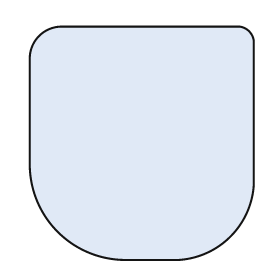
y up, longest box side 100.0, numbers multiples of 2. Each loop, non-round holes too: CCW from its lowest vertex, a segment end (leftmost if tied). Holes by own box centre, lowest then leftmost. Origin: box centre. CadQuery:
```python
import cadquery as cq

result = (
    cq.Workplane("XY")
    .moveTo(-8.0, -50.0)
    .lineTo(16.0, -50.0)
    .threePointArc((38.0, -40.0), (48.0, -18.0))
    .lineTo(48.0, 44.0)
    .threePointArc((46.0, 48.0), (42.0, 50.0))
    .lineTo(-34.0, 50.0)
    .threePointArc((-44.0, 46.0), (-48.0, 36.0))
    .lineTo(-48.0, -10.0)
    .threePointArc((-36.0, -38.0), (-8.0, -50.0))
    .close()
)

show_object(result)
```